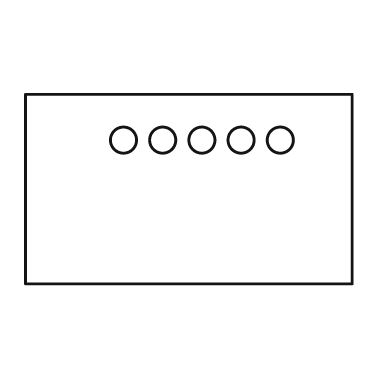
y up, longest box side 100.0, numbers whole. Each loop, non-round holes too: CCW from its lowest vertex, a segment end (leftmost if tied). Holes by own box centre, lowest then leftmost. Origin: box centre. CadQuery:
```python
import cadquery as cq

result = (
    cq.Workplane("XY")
    .moveTo(-50.0, -29.0)
    .lineTo(50.0, -29.0)
    .lineTo(50.0, 29.0)
    .lineTo(-50.0, 29.0)
    .close()
    .moveTo(-20.0, 15.0)
    .circle(4.0)
    .moveTo(-8.0, 15.0)
    .circle(4.0)
    .moveTo(4.0, 15.0)
    .circle(4.0)
    .moveTo(16.0, 15.0)
    .circle(4.0)
    .moveTo(28.0, 15.0)
    .circle(4.0)
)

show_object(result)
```